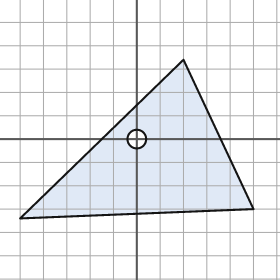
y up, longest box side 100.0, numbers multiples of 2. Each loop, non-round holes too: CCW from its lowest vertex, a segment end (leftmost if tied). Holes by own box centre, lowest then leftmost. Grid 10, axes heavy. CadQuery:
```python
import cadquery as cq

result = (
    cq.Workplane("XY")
    .moveTo(-50.0, -34.0)
    .lineTo(50.0, -30.0)
    .lineTo(20.0, 34.0)
    .close()
    .moveTo(0.0, 0.0)
    .circle(4.0)
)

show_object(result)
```